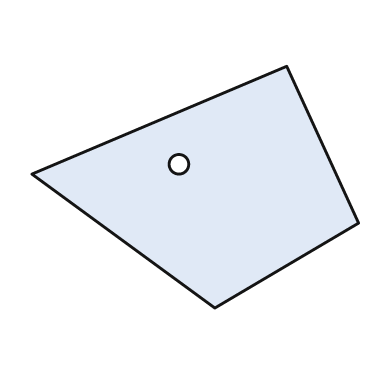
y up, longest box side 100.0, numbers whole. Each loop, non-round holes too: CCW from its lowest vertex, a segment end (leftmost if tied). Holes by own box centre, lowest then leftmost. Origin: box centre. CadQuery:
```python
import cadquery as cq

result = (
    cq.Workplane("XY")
    .moveTo(6.0, -37.0)
    .lineTo(50.0, -11.0)
    .lineTo(28.0, 37.0)
    .lineTo(-50.0, 4.0)
    .close()
    .moveTo(-5.0, 7.0)
    .circle(3.0)
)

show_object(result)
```